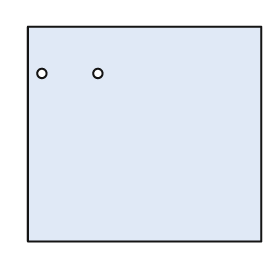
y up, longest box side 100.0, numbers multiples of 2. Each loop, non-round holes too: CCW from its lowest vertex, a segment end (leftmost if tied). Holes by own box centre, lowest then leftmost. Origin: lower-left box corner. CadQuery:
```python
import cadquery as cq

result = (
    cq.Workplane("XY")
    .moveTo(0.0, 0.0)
    .lineTo(100.0, 0.0)
    .lineTo(100.0, 92.0)
    .lineTo(0.0, 92.0)
    .close()
    .moveTo(6.0, 72.0)
    .circle(2.0)
    .moveTo(30.0, 72.0)
    .circle(2.0)
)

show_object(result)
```